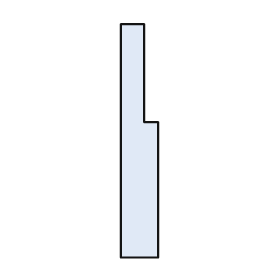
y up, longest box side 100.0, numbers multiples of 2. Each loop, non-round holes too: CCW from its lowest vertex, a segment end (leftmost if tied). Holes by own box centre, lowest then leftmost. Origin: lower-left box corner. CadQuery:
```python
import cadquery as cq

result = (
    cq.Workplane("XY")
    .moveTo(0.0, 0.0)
    .lineTo(16.0, 0.0)
    .lineTo(16.0, 58.0)
    .lineTo(10.0, 58.0)
    .lineTo(10.0, 100.0)
    .lineTo(0.0, 100.0)
    .close()
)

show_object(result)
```